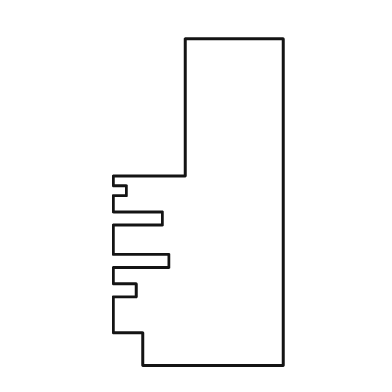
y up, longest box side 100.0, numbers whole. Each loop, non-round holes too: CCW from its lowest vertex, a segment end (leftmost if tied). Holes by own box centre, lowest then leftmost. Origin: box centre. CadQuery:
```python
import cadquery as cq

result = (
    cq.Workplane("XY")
    .moveTo(-17.0, -50.0)
    .lineTo(26.0, -50.0)
    .lineTo(26.0, 50.0)
    .lineTo(-4.0, 50.0)
    .lineTo(-4.0, 8.0)
    .lineTo(-26.0, 8.0)
    .lineTo(-26.0, 5.0)
    .lineTo(-22.0, 5.0)
    .lineTo(-22.0, 2.0)
    .lineTo(-26.0, 2.0)
    .lineTo(-26.0, -3.0)
    .lineTo(-11.0, -3.0)
    .lineTo(-11.0, -7.0)
    .lineTo(-26.0, -7.0)
    .lineTo(-26.0, -16.0)
    .lineTo(-9.0, -16.0)
    .lineTo(-9.0, -20.0)
    .lineTo(-26.0, -20.0)
    .lineTo(-26.0, -25.0)
    .lineTo(-19.0, -25.0)
    .lineTo(-19.0, -29.0)
    .lineTo(-26.0, -29.0)
    .lineTo(-26.0, -40.0)
    .lineTo(-17.0, -40.0)
    .close()
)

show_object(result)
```